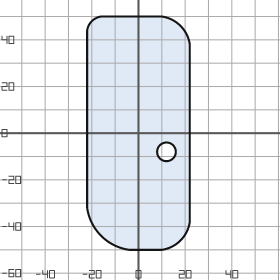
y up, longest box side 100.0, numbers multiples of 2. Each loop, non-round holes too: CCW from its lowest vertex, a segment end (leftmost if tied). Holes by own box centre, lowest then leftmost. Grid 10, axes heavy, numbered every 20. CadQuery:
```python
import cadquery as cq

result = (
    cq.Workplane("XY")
    .moveTo(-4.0, -50.0)
    .lineTo(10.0, -50.0)
    .threePointArc((18.0, -46.0), (22.0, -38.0))
    .lineTo(22.0, 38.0)
    .threePointArc((18.0, 46.0), (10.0, 50.0))
    .lineTo(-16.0, 50.0)
    .threePointArc((-20.0, 48.0), (-22.0, 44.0))
    .lineTo(-22.0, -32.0)
    .threePointArc((-16.0, -44.0), (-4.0, -50.0))
    .close()
    .moveTo(12.0, -8.0)
    .circle(4.0)
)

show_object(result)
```